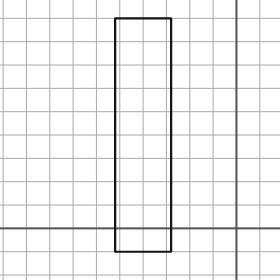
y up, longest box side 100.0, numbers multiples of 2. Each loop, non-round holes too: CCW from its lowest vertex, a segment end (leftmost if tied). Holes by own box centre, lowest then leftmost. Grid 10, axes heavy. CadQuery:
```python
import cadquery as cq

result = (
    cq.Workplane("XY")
    .moveTo(-52.0, -10.0)
    .lineTo(-28.0, -10.0)
    .lineTo(-28.0, 90.0)
    .lineTo(-52.0, 90.0)
    .close()
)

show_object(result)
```